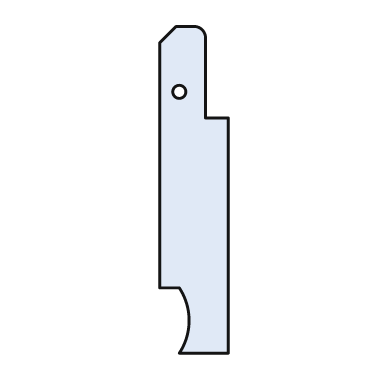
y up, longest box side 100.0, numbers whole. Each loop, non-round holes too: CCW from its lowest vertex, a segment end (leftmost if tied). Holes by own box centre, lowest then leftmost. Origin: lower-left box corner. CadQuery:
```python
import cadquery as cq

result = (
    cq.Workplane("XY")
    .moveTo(6.0, 0.0)
    .lineTo(21.0, 0.0)
    .lineTo(21.0, 72.0)
    .lineTo(14.0, 72.0)
    .lineTo(14.0, 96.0)
    .threePointArc((13.0, 99.0), (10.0, 100.0))
    .lineTo(5.0, 100.0)
    .lineTo(0.0, 95.0)
    .lineTo(0.0, 20.0)
    .lineTo(6.0, 20.0)
    .threePointArc((9.0, 10.0), (6.0, 0.0))
    .close()
    .moveTo(6.0, 80.0)
    .circle(2.0)
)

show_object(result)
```